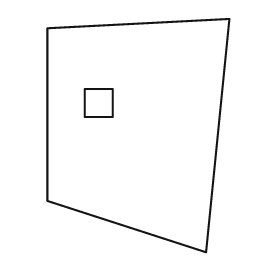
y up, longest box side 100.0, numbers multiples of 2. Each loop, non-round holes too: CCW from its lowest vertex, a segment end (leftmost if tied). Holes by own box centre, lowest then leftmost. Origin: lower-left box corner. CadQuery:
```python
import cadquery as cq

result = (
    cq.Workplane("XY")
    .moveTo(68.0, 0.0)
    .lineTo(78.0, 100.0)
    .lineTo(0.0, 96.0)
    .lineTo(0.0, 22.0)
    .close()
    .moveTo(16.0, 58.0)
    .lineTo(28.0, 58.0)
    .lineTo(28.0, 70.0)
    .lineTo(16.0, 70.0)
    .close()
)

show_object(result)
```